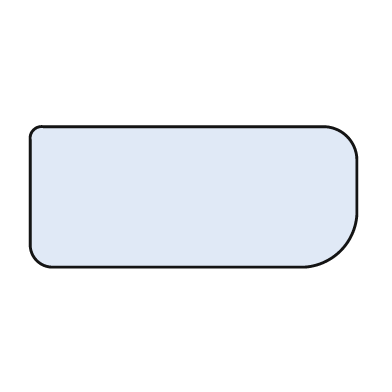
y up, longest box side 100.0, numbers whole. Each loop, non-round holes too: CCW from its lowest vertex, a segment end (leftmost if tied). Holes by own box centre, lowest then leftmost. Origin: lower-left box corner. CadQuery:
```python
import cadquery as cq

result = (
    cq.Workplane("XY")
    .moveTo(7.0, 0.0)
    .lineTo(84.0, 0.0)
    .threePointArc((95.0, 5.0), (100.0, 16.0))
    .lineTo(100.0, 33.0)
    .threePointArc((97.0, 40.0), (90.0, 43.0))
    .lineTo(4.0, 43.0)
    .threePointArc((1.0, 42.0), (0.0, 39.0))
    .lineTo(0.0, 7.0)
    .threePointArc((2.0, 2.0), (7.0, 0.0))
    .close()
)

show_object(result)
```